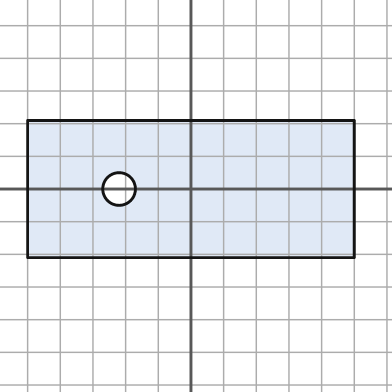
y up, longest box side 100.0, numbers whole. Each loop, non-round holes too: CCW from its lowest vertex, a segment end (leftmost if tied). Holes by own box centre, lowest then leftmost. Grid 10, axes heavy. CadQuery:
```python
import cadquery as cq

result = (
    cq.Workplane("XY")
    .moveTo(-50.0, -21.0)
    .lineTo(50.0, -21.0)
    .lineTo(50.0, 21.0)
    .lineTo(-50.0, 21.0)
    .close()
    .moveTo(-22.0, 0.0)
    .circle(5.0)
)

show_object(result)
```